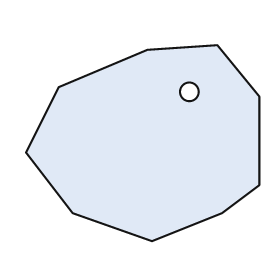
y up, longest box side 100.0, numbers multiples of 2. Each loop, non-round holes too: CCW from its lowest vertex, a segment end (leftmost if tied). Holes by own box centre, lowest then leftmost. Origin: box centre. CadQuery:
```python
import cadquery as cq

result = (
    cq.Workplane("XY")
    .moveTo(4.0, -42.0)
    .lineTo(34.0, -30.0)
    .lineTo(50.0, -18.0)
    .lineTo(50.0, 20.0)
    .lineTo(32.0, 42.0)
    .lineTo(2.0, 40.0)
    .lineTo(-36.0, 24.0)
    .lineTo(-50.0, -4.0)
    .lineTo(-30.0, -30.0)
    .close()
    .moveTo(20.0, 22.0)
    .circle(4.0)
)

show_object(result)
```